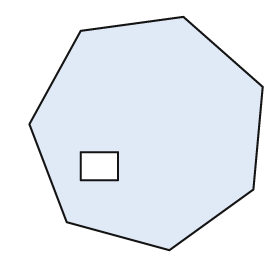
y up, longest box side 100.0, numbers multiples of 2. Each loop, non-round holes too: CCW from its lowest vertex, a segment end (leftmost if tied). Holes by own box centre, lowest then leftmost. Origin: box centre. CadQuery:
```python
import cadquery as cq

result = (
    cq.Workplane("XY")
    .moveTo(10.0, -50.0)
    .lineTo(46.0, -24.0)
    .lineTo(50.0, 20.0)
    .lineTo(16.0, 50.0)
    .lineTo(-28.0, 44.0)
    .lineTo(-50.0, 4.0)
    .lineTo(-34.0, -38.0)
    .close()
    .moveTo(-28.0, -20.0)
    .lineTo(-12.0, -20.0)
    .lineTo(-12.0, -8.0)
    .lineTo(-28.0, -8.0)
    .close()
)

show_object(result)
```